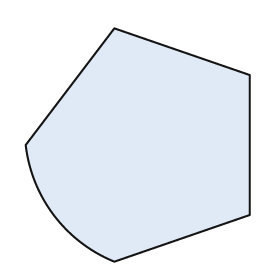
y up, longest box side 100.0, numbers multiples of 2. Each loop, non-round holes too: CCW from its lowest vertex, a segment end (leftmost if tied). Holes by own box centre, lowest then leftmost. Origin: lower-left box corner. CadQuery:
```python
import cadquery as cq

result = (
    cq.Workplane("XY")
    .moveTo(38.0, 0.0)
    .lineTo(96.0, 20.0)
    .lineTo(96.0, 80.0)
    .lineTo(38.0, 100.0)
    .lineTo(0.0, 50.0)
    .threePointArc((12.0, 20.0), (38.0, 0.0))
    .close()
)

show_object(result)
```